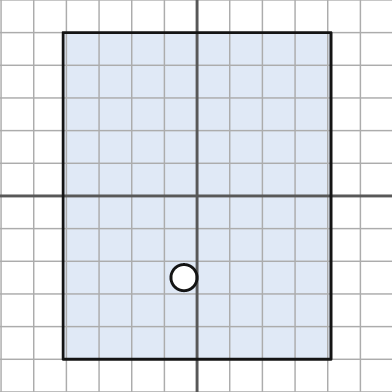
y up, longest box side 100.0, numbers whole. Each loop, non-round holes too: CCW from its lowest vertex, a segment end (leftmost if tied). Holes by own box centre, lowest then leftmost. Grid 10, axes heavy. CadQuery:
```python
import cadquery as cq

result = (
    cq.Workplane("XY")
    .moveTo(-41.0, -50.0)
    .lineTo(41.0, -50.0)
    .lineTo(41.0, 50.0)
    .lineTo(-41.0, 50.0)
    .close()
    .moveTo(-4.0, -25.0)
    .circle(4.0)
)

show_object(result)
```